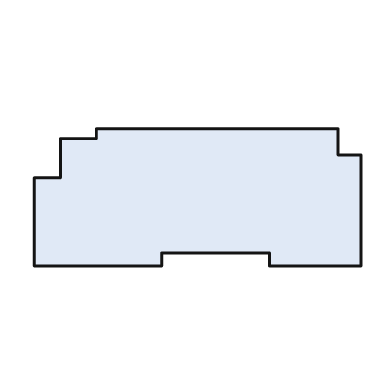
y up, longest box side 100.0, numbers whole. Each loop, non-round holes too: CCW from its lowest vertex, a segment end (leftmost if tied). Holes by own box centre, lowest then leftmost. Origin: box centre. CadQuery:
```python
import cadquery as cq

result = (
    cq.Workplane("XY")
    .moveTo(-50.0, -21.0)
    .lineTo(-11.0, -21.0)
    .lineTo(-11.0, -17.0)
    .lineTo(22.0, -17.0)
    .lineTo(22.0, -21.0)
    .lineTo(50.0, -21.0)
    .lineTo(50.0, 13.0)
    .lineTo(43.0, 13.0)
    .lineTo(43.0, 21.0)
    .lineTo(-31.0, 21.0)
    .lineTo(-31.0, 18.0)
    .lineTo(-42.0, 18.0)
    .lineTo(-42.0, 6.0)
    .lineTo(-50.0, 6.0)
    .close()
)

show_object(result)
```